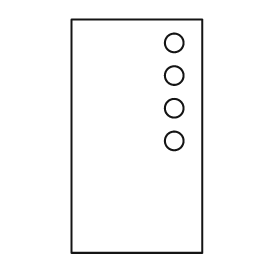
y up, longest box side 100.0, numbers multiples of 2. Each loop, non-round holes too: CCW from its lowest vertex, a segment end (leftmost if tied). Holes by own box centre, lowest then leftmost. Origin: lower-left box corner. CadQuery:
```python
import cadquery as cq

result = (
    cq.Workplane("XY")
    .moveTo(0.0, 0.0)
    .lineTo(56.0, 0.0)
    .lineTo(56.0, 100.0)
    .lineTo(0.0, 100.0)
    .close()
    .moveTo(44.0, 48.0)
    .circle(4.0)
    .moveTo(44.0, 62.0)
    .circle(4.0)
    .moveTo(44.0, 76.0)
    .circle(4.0)
    .moveTo(44.0, 90.0)
    .circle(4.0)
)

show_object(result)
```